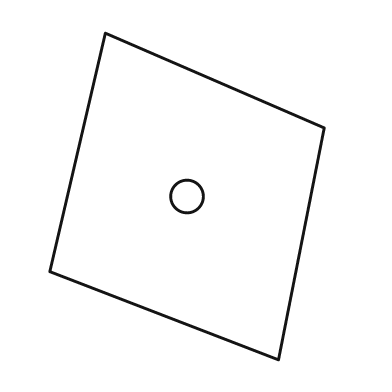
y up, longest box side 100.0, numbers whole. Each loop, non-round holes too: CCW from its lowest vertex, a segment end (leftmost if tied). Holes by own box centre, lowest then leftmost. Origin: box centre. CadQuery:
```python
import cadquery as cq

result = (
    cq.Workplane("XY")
    .moveTo(28.0, -50.0)
    .lineTo(42.0, 21.0)
    .lineTo(-25.0, 50.0)
    .lineTo(-42.0, -23.0)
    .close()
    .moveTo(0.0, 0.0)
    .circle(5.0)
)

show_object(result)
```